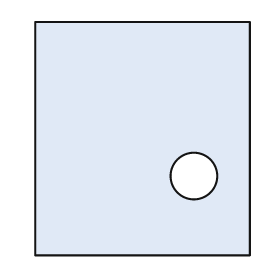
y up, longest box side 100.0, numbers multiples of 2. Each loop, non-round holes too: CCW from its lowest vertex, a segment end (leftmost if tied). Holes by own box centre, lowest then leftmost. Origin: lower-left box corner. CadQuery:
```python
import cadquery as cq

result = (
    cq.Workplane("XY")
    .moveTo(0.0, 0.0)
    .lineTo(92.0, 0.0)
    .lineTo(92.0, 100.0)
    .lineTo(0.0, 100.0)
    .close()
    .moveTo(68.0, 34.0)
    .circle(10.0)
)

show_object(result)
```